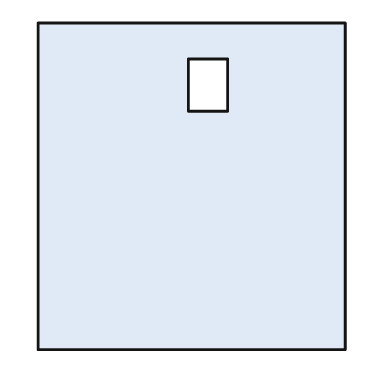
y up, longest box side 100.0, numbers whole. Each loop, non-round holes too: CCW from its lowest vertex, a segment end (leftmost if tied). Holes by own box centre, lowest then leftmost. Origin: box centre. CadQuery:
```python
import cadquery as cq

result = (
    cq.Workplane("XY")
    .moveTo(-47.0, -50.0)
    .lineTo(47.0, -50.0)
    .lineTo(47.0, 50.0)
    .lineTo(-47.0, 50.0)
    .close()
    .moveTo(-1.0, 23.0)
    .lineTo(11.0, 23.0)
    .lineTo(11.0, 39.0)
    .lineTo(-1.0, 39.0)
    .close()
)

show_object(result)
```